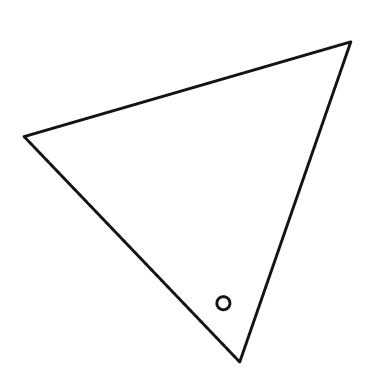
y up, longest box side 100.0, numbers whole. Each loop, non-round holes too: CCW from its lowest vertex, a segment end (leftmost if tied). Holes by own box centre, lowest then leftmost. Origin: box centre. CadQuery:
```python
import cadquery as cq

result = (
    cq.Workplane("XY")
    .moveTo(16.0, -49.0)
    .lineTo(50.0, 49.0)
    .lineTo(-50.0, 20.0)
    .close()
    .moveTo(11.0, -31.0)
    .circle(2.0)
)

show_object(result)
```